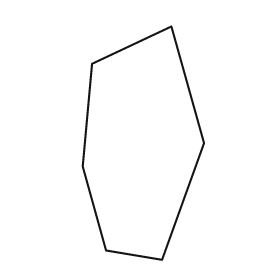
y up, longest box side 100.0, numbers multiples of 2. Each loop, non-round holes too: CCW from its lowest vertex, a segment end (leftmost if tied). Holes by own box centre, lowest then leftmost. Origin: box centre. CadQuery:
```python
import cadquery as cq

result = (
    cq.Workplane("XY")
    .moveTo(8.0, -50.0)
    .lineTo(26.0, 0.0)
    .lineTo(12.0, 50.0)
    .lineTo(-22.0, 34.0)
    .lineTo(-26.0, -10.0)
    .lineTo(-16.0, -46.0)
    .close()
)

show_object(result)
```